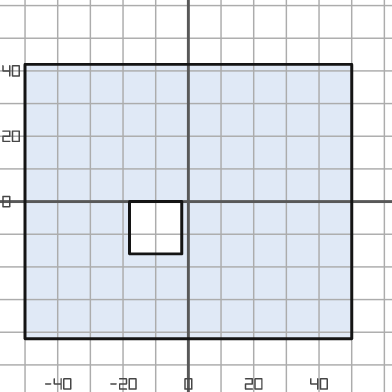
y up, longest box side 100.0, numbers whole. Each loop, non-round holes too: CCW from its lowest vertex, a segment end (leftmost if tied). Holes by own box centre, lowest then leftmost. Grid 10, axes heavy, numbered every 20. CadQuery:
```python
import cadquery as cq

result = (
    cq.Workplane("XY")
    .moveTo(-50.0, -42.0)
    .lineTo(50.0, -42.0)
    .lineTo(50.0, 42.0)
    .lineTo(-50.0, 42.0)
    .close()
    .moveTo(-18.0, -16.0)
    .lineTo(-2.0, -16.0)
    .lineTo(-2.0, 0.0)
    .lineTo(-18.0, 0.0)
    .close()
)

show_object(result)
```